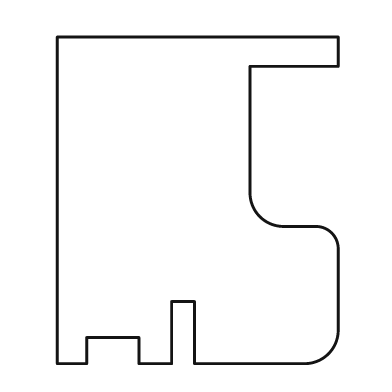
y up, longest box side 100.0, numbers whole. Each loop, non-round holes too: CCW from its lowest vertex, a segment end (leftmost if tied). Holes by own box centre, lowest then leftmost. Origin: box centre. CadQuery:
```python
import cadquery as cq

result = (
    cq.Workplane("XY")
    .moveTo(-43.0, -50.0)
    .lineTo(-34.0, -50.0)
    .lineTo(-34.0, -42.0)
    .lineTo(-18.0, -42.0)
    .lineTo(-18.0, -50.0)
    .lineTo(-8.0, -50.0)
    .lineTo(-8.0, -31.0)
    .lineTo(-1.0, -31.0)
    .lineTo(-1.0, -50.0)
    .lineTo(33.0, -50.0)
    .threePointArc((40.0, -47.0), (43.0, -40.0))
    .lineTo(43.0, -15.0)
    .threePointArc((41.0, -10.0), (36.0, -8.0))
    .lineTo(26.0, -8.0)
    .threePointArc((19.0, -5.0), (16.0, 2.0))
    .lineTo(16.0, 41.0)
    .lineTo(43.0, 41.0)
    .lineTo(43.0, 50.0)
    .lineTo(-43.0, 50.0)
    .close()
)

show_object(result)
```